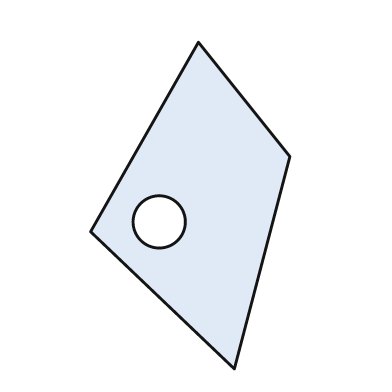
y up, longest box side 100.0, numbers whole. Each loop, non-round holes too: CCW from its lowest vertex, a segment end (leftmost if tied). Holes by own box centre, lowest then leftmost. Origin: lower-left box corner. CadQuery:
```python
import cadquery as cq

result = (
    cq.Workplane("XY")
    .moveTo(44.0, 0.0)
    .lineTo(61.0, 65.0)
    .lineTo(33.0, 100.0)
    .lineTo(0.0, 42.0)
    .close()
    .moveTo(21.0, 45.0)
    .circle(8.0)
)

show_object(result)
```